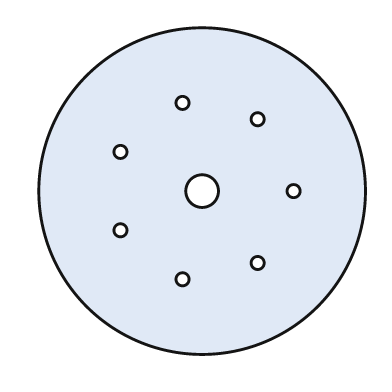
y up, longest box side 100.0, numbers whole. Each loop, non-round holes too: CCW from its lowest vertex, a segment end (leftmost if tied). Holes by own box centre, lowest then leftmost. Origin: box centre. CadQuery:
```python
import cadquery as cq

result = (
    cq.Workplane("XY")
    .moveTo(0.0, 0.0)
    .circle(50.0)
    .moveTo(-6.0, -27.0)
    .circle(2.0)
    .moveTo(17.0, -22.0)
    .circle(2.0)
    .moveTo(-25.0, -12.0)
    .circle(2.0)
    .moveTo(0.0, 0.0)
    .circle(5.0)
    .moveTo(28.0, 0.0)
    .circle(2.0)
    .moveTo(-25.0, 12.0)
    .circle(2.0)
    .moveTo(17.0, 22.0)
    .circle(2.0)
    .moveTo(-6.0, 27.0)
    .circle(2.0)
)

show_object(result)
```